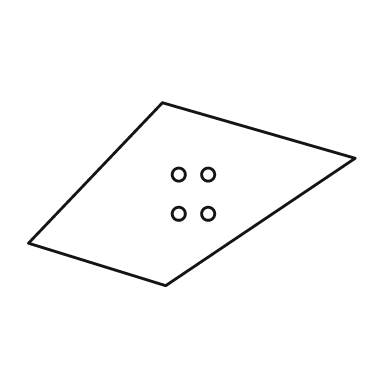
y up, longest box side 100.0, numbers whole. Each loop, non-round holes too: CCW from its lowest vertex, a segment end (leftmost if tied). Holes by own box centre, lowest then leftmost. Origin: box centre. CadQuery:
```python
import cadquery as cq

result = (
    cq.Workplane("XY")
    .moveTo(-8.0, -28.0)
    .lineTo(50.0, 11.0)
    .lineTo(-9.0, 28.0)
    .lineTo(-50.0, -15.0)
    .close()
    .moveTo(-4.0, -6.0)
    .circle(2.0)
    .moveTo(5.0, -6.0)
    .circle(2.0)
    .moveTo(-4.0, 6.0)
    .circle(2.0)
    .moveTo(5.0, 6.0)
    .circle(2.0)
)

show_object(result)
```